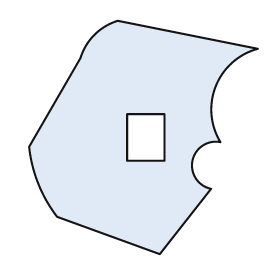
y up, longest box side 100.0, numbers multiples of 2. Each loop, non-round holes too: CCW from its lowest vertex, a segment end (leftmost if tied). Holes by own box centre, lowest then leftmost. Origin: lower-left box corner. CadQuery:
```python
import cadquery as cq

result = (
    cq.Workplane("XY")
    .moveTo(56.0, 0.0)
    .lineTo(78.0, 28.0)
    .threePointArc((70.0, 40.0), (82.0, 48.0))
    .threePointArc((80.0, 72.0), (98.0, 88.0))
    .lineTo(38.0, 100.0)
    .threePointArc((28.0, 94.0), (22.0, 84.0))
    .lineTo(0.0, 46.0)
    .threePointArc((4.0, 30.0), (12.0, 16.0))
    .close()
    .moveTo(42.0, 40.0)
    .lineTo(58.0, 40.0)
    .lineTo(58.0, 60.0)
    .lineTo(42.0, 60.0)
    .close()
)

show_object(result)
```